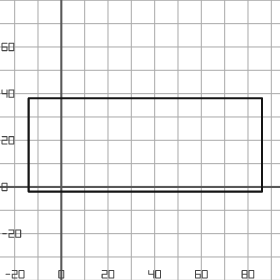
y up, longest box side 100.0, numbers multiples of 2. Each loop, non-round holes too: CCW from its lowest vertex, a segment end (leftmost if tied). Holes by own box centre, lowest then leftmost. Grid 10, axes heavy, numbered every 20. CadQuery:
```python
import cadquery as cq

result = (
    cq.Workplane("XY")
    .moveTo(-14.0, -2.0)
    .lineTo(86.0, -2.0)
    .lineTo(86.0, 38.0)
    .lineTo(-14.0, 38.0)
    .close()
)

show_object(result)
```